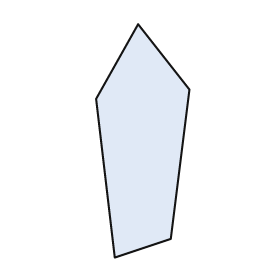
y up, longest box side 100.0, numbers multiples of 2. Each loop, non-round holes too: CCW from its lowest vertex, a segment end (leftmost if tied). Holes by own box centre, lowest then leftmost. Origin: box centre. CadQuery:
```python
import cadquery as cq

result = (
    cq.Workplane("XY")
    .moveTo(-12.0, -50.0)
    .lineTo(12.0, -42.0)
    .lineTo(20.0, 22.0)
    .lineTo(-2.0, 50.0)
    .lineTo(-20.0, 18.0)
    .close()
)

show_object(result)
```